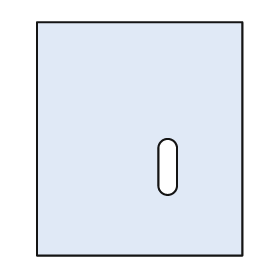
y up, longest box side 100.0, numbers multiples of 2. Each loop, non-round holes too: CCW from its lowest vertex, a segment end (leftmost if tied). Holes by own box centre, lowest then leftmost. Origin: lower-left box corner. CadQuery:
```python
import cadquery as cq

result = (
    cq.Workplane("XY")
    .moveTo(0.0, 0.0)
    .lineTo(88.0, 0.0)
    .lineTo(88.0, 100.0)
    .lineTo(0.0, 100.0)
    .close()
    .moveTo(52.0, 30.0)
    .threePointArc((56.0, 26.0), (60.0, 30.0))
    .lineTo(60.0, 46.0)
    .threePointArc((56.0, 50.0), (52.0, 46.0))
    .close()
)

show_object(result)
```